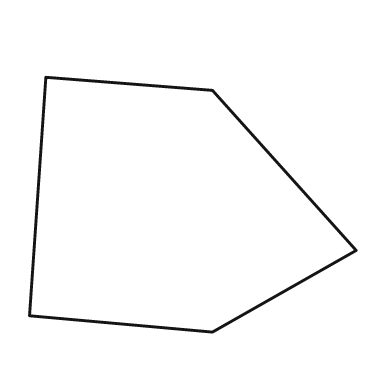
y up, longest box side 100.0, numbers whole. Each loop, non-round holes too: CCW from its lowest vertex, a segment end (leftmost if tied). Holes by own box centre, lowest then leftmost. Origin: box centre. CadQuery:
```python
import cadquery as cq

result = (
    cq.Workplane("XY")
    .moveTo(6.0, -39.0)
    .lineTo(50.0, -14.0)
    .lineTo(6.0, 35.0)
    .lineTo(-45.0, 39.0)
    .lineTo(-50.0, -34.0)
    .close()
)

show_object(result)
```